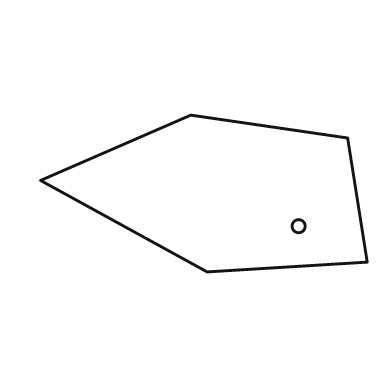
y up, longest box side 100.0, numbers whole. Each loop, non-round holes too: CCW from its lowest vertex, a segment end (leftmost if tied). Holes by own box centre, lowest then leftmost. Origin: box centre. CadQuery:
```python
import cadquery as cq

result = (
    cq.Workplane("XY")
    .moveTo(1.0, -24.0)
    .lineTo(50.0, -21.0)
    .lineTo(44.0, 17.0)
    .lineTo(-4.0, 24.0)
    .lineTo(-50.0, 4.0)
    .close()
    .moveTo(29.0, -10.0)
    .circle(2.0)
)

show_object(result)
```